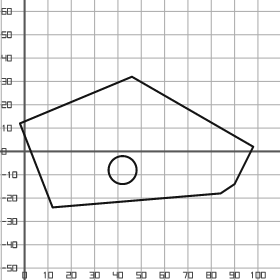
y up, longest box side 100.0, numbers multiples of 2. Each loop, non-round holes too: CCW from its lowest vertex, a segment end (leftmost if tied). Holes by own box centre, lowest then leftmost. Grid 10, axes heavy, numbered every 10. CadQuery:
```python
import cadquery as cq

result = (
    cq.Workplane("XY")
    .moveTo(12.0, -24.0)
    .lineTo(84.0, -18.0)
    .lineTo(90.0, -14.0)
    .lineTo(98.0, 2.0)
    .lineTo(46.0, 32.0)
    .lineTo(-2.0, 12.0)
    .close()
    .moveTo(42.0, -8.0)
    .circle(6.0)
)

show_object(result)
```